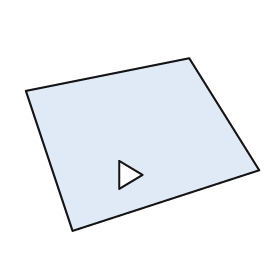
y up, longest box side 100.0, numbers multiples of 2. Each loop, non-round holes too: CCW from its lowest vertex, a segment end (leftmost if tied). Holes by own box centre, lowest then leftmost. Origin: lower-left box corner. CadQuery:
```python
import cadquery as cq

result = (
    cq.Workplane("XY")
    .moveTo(20.0, 0.0)
    .lineTo(100.0, 26.0)
    .lineTo(70.0, 74.0)
    .lineTo(0.0, 60.0)
    .close()
    .moveTo(40.0, 18.0)
    .lineTo(50.0, 24.0)
    .lineTo(40.0, 30.0)
    .close()
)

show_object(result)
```